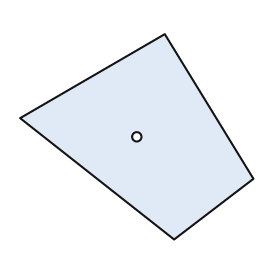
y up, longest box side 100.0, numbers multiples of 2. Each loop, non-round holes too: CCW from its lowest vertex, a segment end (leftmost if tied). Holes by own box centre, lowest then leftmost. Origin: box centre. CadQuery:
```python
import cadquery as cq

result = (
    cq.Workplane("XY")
    .moveTo(16.0, -44.0)
    .lineTo(50.0, -18.0)
    .lineTo(12.0, 44.0)
    .lineTo(-50.0, 8.0)
    .close()
    .moveTo(0.0, 0.0)
    .circle(2.0)
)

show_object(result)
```